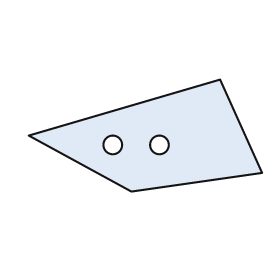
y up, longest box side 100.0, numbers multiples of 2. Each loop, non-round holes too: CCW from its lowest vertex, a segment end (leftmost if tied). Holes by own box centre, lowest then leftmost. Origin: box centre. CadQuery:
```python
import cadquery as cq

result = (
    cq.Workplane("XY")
    .moveTo(-6.0, -24.0)
    .lineTo(50.0, -16.0)
    .lineTo(32.0, 24.0)
    .lineTo(-50.0, 0.0)
    .close()
    .moveTo(-14.0, -4.0)
    .circle(4.0)
    .moveTo(6.0, -4.0)
    .circle(4.0)
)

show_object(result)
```